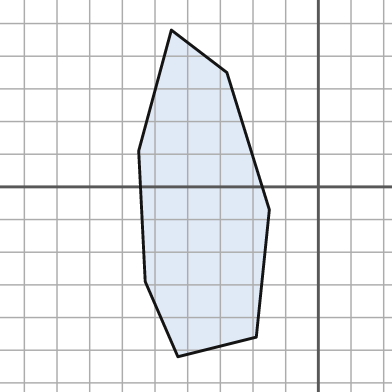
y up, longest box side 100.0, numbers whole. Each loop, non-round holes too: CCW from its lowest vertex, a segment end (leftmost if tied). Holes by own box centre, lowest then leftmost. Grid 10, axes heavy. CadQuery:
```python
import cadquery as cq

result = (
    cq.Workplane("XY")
    .moveTo(-43.0, -52.0)
    .lineTo(-19.0, -46.0)
    .lineTo(-15.0, -7.0)
    .lineTo(-28.0, 35.0)
    .lineTo(-45.0, 48.0)
    .lineTo(-55.0, 11.0)
    .lineTo(-53.0, -29.0)
    .close()
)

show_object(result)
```